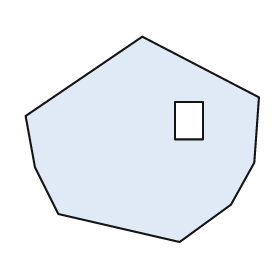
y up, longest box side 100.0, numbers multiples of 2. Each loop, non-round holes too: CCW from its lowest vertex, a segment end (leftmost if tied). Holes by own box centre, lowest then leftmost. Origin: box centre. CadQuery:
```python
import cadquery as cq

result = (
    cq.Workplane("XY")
    .moveTo(16.0, -44.0)
    .lineTo(38.0, -28.0)
    .lineTo(48.0, -10.0)
    .lineTo(50.0, 18.0)
    .lineTo(0.0, 44.0)
    .lineTo(-50.0, 10.0)
    .lineTo(-46.0, -12.0)
    .lineTo(-36.0, -32.0)
    .close()
    .moveTo(14.0, 0.0)
    .lineTo(26.0, 0.0)
    .lineTo(26.0, 16.0)
    .lineTo(14.0, 16.0)
    .close()
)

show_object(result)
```